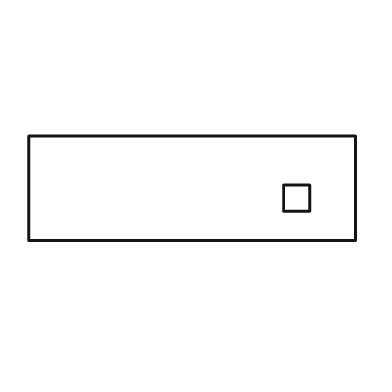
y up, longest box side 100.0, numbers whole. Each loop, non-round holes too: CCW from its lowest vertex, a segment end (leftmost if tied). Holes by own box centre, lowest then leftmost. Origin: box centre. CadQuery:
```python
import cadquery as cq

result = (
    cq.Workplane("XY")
    .moveTo(-50.0, -16.0)
    .lineTo(50.0, -16.0)
    .lineTo(50.0, 16.0)
    .lineTo(-50.0, 16.0)
    .close()
    .moveTo(28.0, -7.0)
    .lineTo(36.0, -7.0)
    .lineTo(36.0, 1.0)
    .lineTo(28.0, 1.0)
    .close()
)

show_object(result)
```